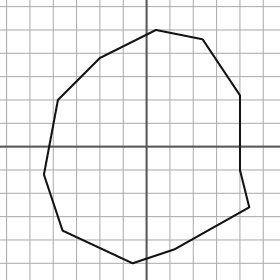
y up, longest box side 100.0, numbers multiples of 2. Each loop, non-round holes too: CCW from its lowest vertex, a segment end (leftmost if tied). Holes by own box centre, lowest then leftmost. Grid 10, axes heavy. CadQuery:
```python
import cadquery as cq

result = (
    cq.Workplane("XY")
    .moveTo(-6.0, -50.0)
    .lineTo(12.0, -44.0)
    .lineTo(44.0, -26.0)
    .lineTo(40.0, -10.0)
    .lineTo(40.0, 22.0)
    .lineTo(24.0, 46.0)
    .lineTo(4.0, 50.0)
    .lineTo(-20.0, 38.0)
    .lineTo(-38.0, 20.0)
    .lineTo(-44.0, -12.0)
    .lineTo(-36.0, -36.0)
    .close()
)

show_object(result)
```